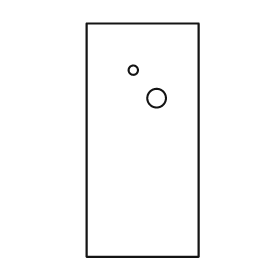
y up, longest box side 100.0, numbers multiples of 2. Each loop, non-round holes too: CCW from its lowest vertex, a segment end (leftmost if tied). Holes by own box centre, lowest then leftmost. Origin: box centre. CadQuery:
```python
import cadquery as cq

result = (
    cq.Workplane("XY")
    .moveTo(-24.0, -50.0)
    .lineTo(24.0, -50.0)
    .lineTo(24.0, 50.0)
    .lineTo(-24.0, 50.0)
    .close()
    .moveTo(6.0, 18.0)
    .circle(4.0)
    .moveTo(-4.0, 30.0)
    .circle(2.0)
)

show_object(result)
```